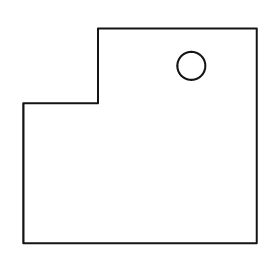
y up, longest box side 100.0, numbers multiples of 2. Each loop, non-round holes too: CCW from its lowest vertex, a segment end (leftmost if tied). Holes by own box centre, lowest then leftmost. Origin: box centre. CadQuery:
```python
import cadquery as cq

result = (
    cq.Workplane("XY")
    .moveTo(-50.0, -46.0)
    .lineTo(50.0, -46.0)
    .lineTo(50.0, 46.0)
    .lineTo(-18.0, 46.0)
    .lineTo(-18.0, 14.0)
    .lineTo(-50.0, 14.0)
    .close()
    .moveTo(22.0, 30.0)
    .circle(6.0)
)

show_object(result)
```